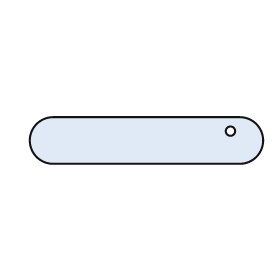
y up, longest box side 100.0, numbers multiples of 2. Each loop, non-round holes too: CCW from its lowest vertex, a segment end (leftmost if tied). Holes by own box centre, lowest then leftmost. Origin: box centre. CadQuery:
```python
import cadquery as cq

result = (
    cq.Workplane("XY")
    .moveTo(-40.0, -10.0)
    .lineTo(40.0, -10.0)
    .threePointArc((50.0, 0.0), (40.0, 10.0))
    .lineTo(-40.0, 10.0)
    .threePointArc((-50.0, 0.0), (-40.0, -10.0))
    .close()
    .moveTo(36.0, 4.0)
    .circle(2.0)
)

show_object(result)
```